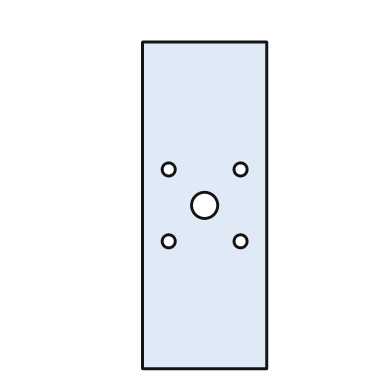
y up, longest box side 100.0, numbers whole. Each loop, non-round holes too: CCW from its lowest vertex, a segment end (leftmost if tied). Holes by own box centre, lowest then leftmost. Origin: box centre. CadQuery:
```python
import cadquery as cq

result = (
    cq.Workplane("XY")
    .moveTo(-19.0, -50.0)
    .lineTo(19.0, -50.0)
    .lineTo(19.0, 50.0)
    .lineTo(-19.0, 50.0)
    .close()
    .moveTo(-11.0, -11.0)
    .circle(2.0)
    .moveTo(11.0, -11.0)
    .circle(2.0)
    .moveTo(0.0, 0.0)
    .circle(4.0)
    .moveTo(-11.0, 11.0)
    .circle(2.0)
    .moveTo(11.0, 11.0)
    .circle(2.0)
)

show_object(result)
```